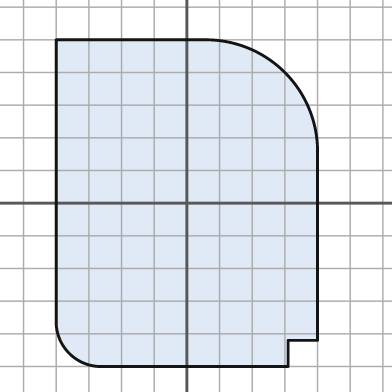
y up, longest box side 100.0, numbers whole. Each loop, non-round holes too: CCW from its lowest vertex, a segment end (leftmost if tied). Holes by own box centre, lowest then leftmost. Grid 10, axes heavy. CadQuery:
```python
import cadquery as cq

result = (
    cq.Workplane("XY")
    .moveTo(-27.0, -50.0)
    .lineTo(31.0, -50.0)
    .lineTo(31.0, -42.0)
    .lineTo(40.0, -42.0)
    .lineTo(40.0, 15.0)
    .threePointArc((30.0, 40.0), (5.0, 50.0))
    .lineTo(-40.0, 50.0)
    .lineTo(-40.0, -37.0)
    .threePointArc((-36.0, -46.0), (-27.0, -50.0))
    .close()
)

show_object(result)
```